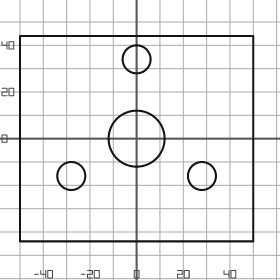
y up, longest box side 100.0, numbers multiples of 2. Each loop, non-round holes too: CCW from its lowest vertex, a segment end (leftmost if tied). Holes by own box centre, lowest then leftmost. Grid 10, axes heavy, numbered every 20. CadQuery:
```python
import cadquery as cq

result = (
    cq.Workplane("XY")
    .moveTo(-50.0, -44.0)
    .lineTo(50.0, -44.0)
    .lineTo(50.0, 44.0)
    .lineTo(-50.0, 44.0)
    .close()
    .moveTo(-28.0, -16.0)
    .circle(6.0)
    .moveTo(28.0, -16.0)
    .circle(6.0)
    .moveTo(0.0, 0.0)
    .circle(12.0)
    .moveTo(0.0, 34.0)
    .circle(6.0)
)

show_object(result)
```